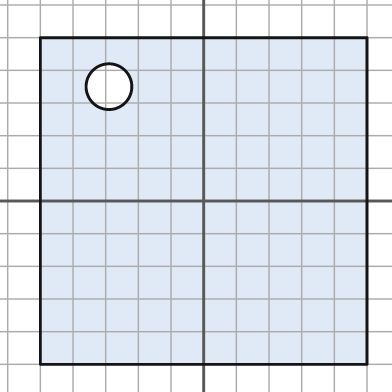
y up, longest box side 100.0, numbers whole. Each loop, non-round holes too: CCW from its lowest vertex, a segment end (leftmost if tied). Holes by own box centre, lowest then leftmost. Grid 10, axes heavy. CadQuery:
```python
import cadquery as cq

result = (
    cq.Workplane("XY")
    .moveTo(-50.0, -50.0)
    .lineTo(50.0, -50.0)
    .lineTo(50.0, 50.0)
    .lineTo(-50.0, 50.0)
    .close()
    .moveTo(-29.0, 35.0)
    .circle(7.0)
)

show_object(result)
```